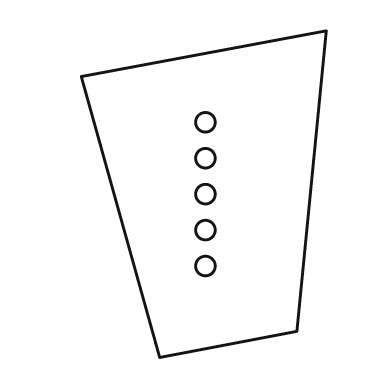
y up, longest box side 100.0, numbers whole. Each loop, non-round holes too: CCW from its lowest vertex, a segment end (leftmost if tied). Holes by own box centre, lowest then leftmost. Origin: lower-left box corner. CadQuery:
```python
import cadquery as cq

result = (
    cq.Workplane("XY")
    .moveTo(24.0, 0.0)
    .lineTo(66.0, 8.0)
    .lineTo(75.0, 100.0)
    .lineTo(0.0, 86.0)
    .close()
    .moveTo(38.0, 28.0)
    .circle(3.0)
    .moveTo(38.0, 39.0)
    .circle(3.0)
    .moveTo(38.0, 50.0)
    .circle(3.0)
    .moveTo(38.0, 61.0)
    .circle(3.0)
    .moveTo(38.0, 72.0)
    .circle(3.0)
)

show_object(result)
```